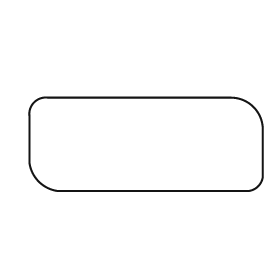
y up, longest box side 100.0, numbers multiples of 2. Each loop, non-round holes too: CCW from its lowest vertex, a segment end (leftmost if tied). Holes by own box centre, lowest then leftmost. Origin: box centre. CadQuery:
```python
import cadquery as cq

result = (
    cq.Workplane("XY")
    .moveTo(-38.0, -20.0)
    .lineTo(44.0, -20.0)
    .threePointArc((48.0, -18.0), (50.0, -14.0))
    .lineTo(50.0, 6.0)
    .threePointArc((46.0, 16.0), (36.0, 20.0))
    .lineTo(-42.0, 20.0)
    .threePointArc((-48.0, 18.0), (-50.0, 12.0))
    .lineTo(-50.0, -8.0)
    .threePointArc((-46.0, -16.0), (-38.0, -20.0))
    .close()
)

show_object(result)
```